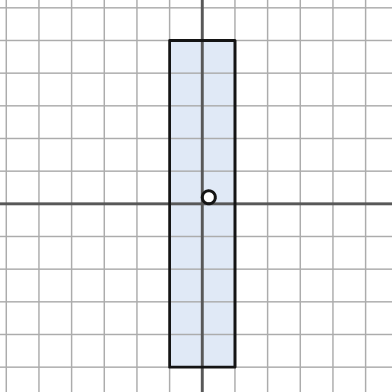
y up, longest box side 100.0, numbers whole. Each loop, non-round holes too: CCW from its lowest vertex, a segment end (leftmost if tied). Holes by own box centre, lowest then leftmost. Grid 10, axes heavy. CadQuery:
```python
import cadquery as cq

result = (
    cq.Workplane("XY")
    .moveTo(-10.0, -50.0)
    .lineTo(10.0, -50.0)
    .lineTo(10.0, 50.0)
    .lineTo(-10.0, 50.0)
    .close()
    .moveTo(2.0, 2.0)
    .circle(2.0)
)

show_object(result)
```